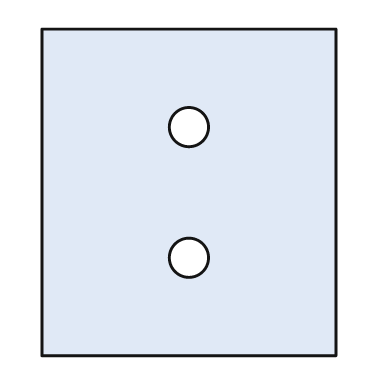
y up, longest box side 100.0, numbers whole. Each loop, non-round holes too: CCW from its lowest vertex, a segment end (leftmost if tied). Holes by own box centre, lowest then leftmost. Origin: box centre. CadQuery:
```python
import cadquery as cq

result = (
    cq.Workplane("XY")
    .moveTo(-45.0, -50.0)
    .lineTo(45.0, -50.0)
    .lineTo(45.0, 50.0)
    .lineTo(-45.0, 50.0)
    .close()
    .moveTo(0.0, -20.0)
    .circle(6.0)
    .moveTo(0.0, 20.0)
    .circle(6.0)
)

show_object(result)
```